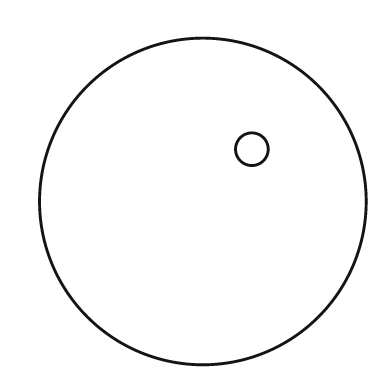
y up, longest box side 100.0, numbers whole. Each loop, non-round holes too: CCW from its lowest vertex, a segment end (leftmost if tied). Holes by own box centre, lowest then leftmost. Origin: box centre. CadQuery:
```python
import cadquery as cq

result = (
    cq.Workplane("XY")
    .moveTo(0.0, 0.0)
    .circle(50.0)
    .moveTo(15.0, 16.0)
    .circle(5.0)
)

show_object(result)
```